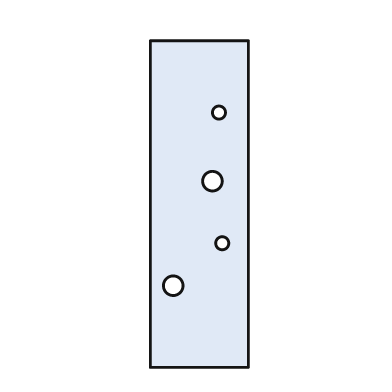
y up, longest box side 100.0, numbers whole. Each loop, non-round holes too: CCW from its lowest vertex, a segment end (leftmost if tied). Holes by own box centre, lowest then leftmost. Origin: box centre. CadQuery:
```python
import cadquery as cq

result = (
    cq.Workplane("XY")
    .moveTo(-15.0, -50.0)
    .lineTo(15.0, -50.0)
    .lineTo(15.0, 50.0)
    .lineTo(-15.0, 50.0)
    .close()
    .moveTo(-8.0, -25.0)
    .circle(3.0)
    .moveTo(7.0, -12.0)
    .circle(2.0)
    .moveTo(4.0, 7.0)
    .circle(3.0)
    .moveTo(6.0, 28.0)
    .circle(2.0)
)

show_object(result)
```